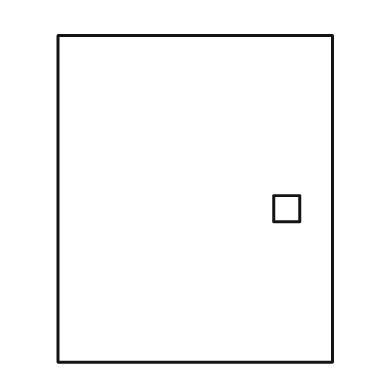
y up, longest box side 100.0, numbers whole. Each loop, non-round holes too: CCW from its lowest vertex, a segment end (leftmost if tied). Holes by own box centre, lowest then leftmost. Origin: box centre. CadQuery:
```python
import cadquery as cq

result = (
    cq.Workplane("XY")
    .moveTo(-42.0, -50.0)
    .lineTo(42.0, -50.0)
    .lineTo(42.0, 50.0)
    .lineTo(-42.0, 50.0)
    .close()
    .moveTo(24.0, -7.0)
    .lineTo(32.0, -7.0)
    .lineTo(32.0, 1.0)
    .lineTo(24.0, 1.0)
    .close()
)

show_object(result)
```